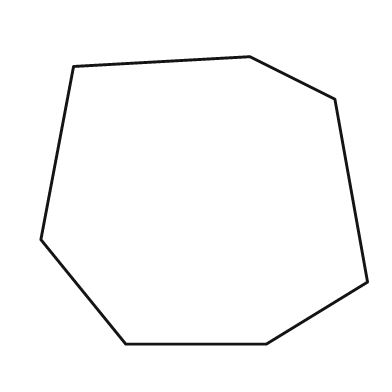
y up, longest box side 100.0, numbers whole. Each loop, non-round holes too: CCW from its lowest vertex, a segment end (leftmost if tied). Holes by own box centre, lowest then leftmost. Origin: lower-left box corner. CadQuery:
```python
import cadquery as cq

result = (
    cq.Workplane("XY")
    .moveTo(26.0, 0.0)
    .lineTo(69.0, 0.0)
    .lineTo(100.0, 19.0)
    .lineTo(90.0, 75.0)
    .lineTo(64.0, 88.0)
    .lineTo(10.0, 85.0)
    .lineTo(0.0, 32.0)
    .close()
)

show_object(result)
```